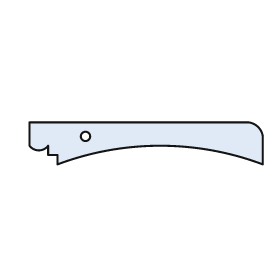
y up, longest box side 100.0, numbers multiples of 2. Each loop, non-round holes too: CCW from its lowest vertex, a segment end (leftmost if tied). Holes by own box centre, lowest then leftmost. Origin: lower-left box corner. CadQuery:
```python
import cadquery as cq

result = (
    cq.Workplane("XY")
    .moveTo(12.0, 0.0)
    .threePointArc((56.0, 8.0), (100.0, 0.0))
    .lineTo(100.0, 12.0)
    .threePointArc((98.0, 16.0), (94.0, 18.0))
    .lineTo(0.0, 18.0)
    .lineTo(0.0, 8.0)
    .threePointArc((4.0, 6.0), (8.0, 8.0))
    .lineTo(8.0, 4.0)
    .lineTo(12.0, 4.0)
    .close()
    .moveTo(24.0, 12.0)
    .circle(2.0)
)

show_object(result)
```